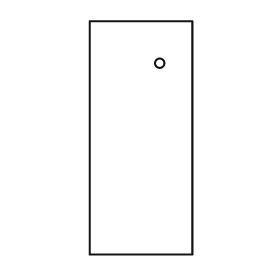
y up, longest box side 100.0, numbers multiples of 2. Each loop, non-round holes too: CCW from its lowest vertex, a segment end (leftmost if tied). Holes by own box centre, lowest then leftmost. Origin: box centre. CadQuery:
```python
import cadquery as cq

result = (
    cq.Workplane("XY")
    .moveTo(-22.0, -50.0)
    .lineTo(22.0, -50.0)
    .lineTo(22.0, 50.0)
    .lineTo(-22.0, 50.0)
    .close()
    .moveTo(8.0, 32.0)
    .circle(2.0)
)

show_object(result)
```